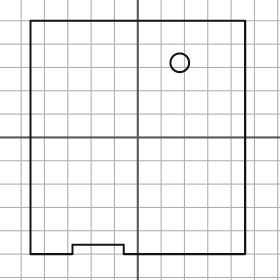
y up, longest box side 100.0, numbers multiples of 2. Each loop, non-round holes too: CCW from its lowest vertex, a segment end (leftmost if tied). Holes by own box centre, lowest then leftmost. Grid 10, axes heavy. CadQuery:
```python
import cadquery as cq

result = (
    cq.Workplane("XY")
    .moveTo(-46.0, -50.0)
    .lineTo(-28.0, -50.0)
    .lineTo(-28.0, -46.0)
    .lineTo(-6.0, -46.0)
    .lineTo(-6.0, -50.0)
    .lineTo(46.0, -50.0)
    .lineTo(46.0, 50.0)
    .lineTo(-46.0, 50.0)
    .close()
    .moveTo(18.0, 32.0)
    .circle(4.0)
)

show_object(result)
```